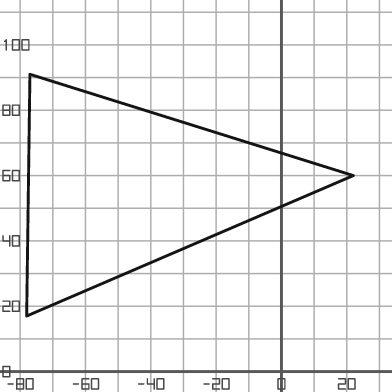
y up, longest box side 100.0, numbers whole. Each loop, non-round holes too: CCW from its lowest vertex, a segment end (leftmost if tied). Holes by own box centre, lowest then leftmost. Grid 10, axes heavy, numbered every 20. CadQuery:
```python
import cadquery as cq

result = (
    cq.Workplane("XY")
    .moveTo(-78.0, 17.0)
    .lineTo(22.0, 60.0)
    .lineTo(-77.0, 91.0)
    .close()
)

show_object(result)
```